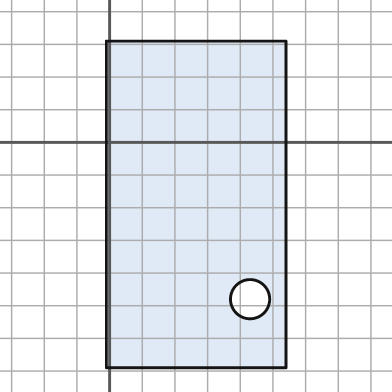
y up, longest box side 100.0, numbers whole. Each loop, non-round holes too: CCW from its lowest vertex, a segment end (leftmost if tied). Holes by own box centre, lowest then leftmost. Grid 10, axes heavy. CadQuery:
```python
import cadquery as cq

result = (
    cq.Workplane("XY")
    .moveTo(-1.0, -69.0)
    .lineTo(54.0, -69.0)
    .lineTo(54.0, 31.0)
    .lineTo(-1.0, 31.0)
    .close()
    .moveTo(43.0, -48.0)
    .circle(6.0)
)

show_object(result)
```